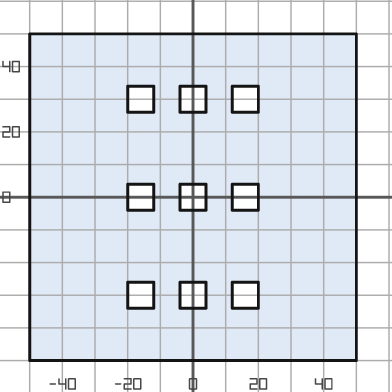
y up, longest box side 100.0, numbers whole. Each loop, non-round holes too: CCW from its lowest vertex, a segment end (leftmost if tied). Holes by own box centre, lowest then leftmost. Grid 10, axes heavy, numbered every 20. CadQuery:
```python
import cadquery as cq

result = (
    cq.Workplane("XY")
    .moveTo(-50.0, -50.0)
    .lineTo(50.0, -50.0)
    .lineTo(50.0, 50.0)
    .lineTo(-50.0, 50.0)
    .close()
    .moveTo(-20.0, -34.0)
    .lineTo(-12.0, -34.0)
    .lineTo(-12.0, -26.0)
    .lineTo(-20.0, -26.0)
    .close()
    .moveTo(-4.0, -34.0)
    .lineTo(4.0, -34.0)
    .lineTo(4.0, -26.0)
    .lineTo(-4.0, -26.0)
    .close()
    .moveTo(12.0, -34.0)
    .lineTo(20.0, -34.0)
    .lineTo(20.0, -26.0)
    .lineTo(12.0, -26.0)
    .close()
    .moveTo(-20.0, -4.0)
    .lineTo(-12.0, -4.0)
    .lineTo(-12.0, 4.0)
    .lineTo(-20.0, 4.0)
    .close()
    .moveTo(-4.0, -4.0)
    .lineTo(4.0, -4.0)
    .lineTo(4.0, 4.0)
    .lineTo(-4.0, 4.0)
    .close()
    .moveTo(12.0, -4.0)
    .lineTo(20.0, -4.0)
    .lineTo(20.0, 4.0)
    .lineTo(12.0, 4.0)
    .close()
    .moveTo(-20.0, 26.0)
    .lineTo(-12.0, 26.0)
    .lineTo(-12.0, 34.0)
    .lineTo(-20.0, 34.0)
    .close()
    .moveTo(-4.0, 26.0)
    .lineTo(4.0, 26.0)
    .lineTo(4.0, 34.0)
    .lineTo(-4.0, 34.0)
    .close()
    .moveTo(12.0, 26.0)
    .lineTo(20.0, 26.0)
    .lineTo(20.0, 34.0)
    .lineTo(12.0, 34.0)
    .close()
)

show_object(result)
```